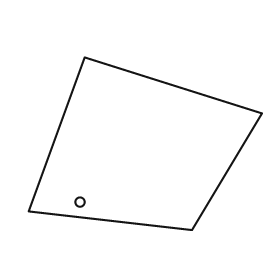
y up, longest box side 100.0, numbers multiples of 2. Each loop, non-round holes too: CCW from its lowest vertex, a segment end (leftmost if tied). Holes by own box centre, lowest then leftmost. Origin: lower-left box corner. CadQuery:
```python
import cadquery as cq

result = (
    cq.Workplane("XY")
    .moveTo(70.0, 0.0)
    .lineTo(100.0, 50.0)
    .lineTo(24.0, 74.0)
    .lineTo(0.0, 8.0)
    .close()
    .moveTo(22.0, 12.0)
    .circle(2.0)
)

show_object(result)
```